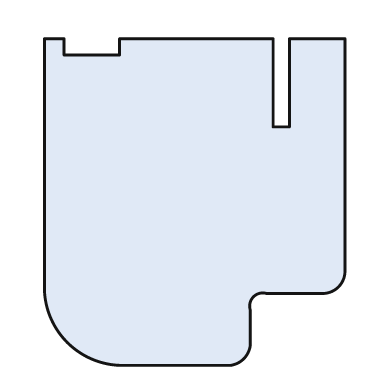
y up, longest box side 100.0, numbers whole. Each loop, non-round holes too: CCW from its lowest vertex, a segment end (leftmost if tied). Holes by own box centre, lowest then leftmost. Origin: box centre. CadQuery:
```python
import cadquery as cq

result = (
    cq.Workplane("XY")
    .moveTo(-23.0, -50.0)
    .lineTo(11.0, -50.0)
    .threePointArc((15.0, -48.0), (17.0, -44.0))
    .lineTo(17.0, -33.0)
    .threePointArc((18.0, -29.0), (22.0, -28.0))
    .lineTo(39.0, -28.0)
    .threePointArc((44.0, -26.0), (46.0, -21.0))
    .lineTo(46.0, 50.0)
    .lineTo(29.0, 50.0)
    .lineTo(29.0, 23.0)
    .lineTo(24.0, 23.0)
    .lineTo(24.0, 50.0)
    .lineTo(-23.0, 50.0)
    .lineTo(-23.0, 45.0)
    .lineTo(-40.0, 45.0)
    .lineTo(-40.0, 50.0)
    .lineTo(-46.0, 50.0)
    .lineTo(-46.0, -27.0)
    .threePointArc((-39.0, -43.0), (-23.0, -50.0))
    .close()
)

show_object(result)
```